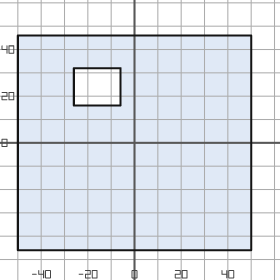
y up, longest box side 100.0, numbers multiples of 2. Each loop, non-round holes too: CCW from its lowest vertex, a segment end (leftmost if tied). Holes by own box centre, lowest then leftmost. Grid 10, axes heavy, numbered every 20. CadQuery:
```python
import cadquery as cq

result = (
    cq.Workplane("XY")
    .moveTo(-50.0, -46.0)
    .lineTo(50.0, -46.0)
    .lineTo(50.0, 46.0)
    .lineTo(-50.0, 46.0)
    .close()
    .moveTo(-26.0, 16.0)
    .lineTo(-6.0, 16.0)
    .lineTo(-6.0, 32.0)
    .lineTo(-26.0, 32.0)
    .close()
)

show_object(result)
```